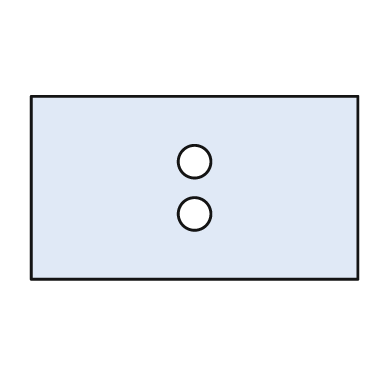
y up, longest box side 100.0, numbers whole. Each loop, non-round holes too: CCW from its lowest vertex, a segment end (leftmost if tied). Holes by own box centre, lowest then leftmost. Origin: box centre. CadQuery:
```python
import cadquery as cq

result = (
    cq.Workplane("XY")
    .moveTo(-50.0, -28.0)
    .lineTo(50.0, -28.0)
    .lineTo(50.0, 28.0)
    .lineTo(-50.0, 28.0)
    .close()
    .moveTo(0.0, -8.0)
    .circle(5.0)
    .moveTo(0.0, 8.0)
    .circle(5.0)
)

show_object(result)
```